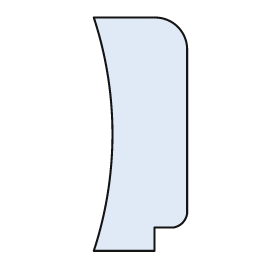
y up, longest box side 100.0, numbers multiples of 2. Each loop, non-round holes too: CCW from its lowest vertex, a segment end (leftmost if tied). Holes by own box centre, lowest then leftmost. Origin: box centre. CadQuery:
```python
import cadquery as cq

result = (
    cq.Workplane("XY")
    .moveTo(-20.0, -50.0)
    .lineTo(6.0, -50.0)
    .lineTo(6.0, -40.0)
    .lineTo(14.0, -40.0)
    .threePointArc((18.0, -38.0), (20.0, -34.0))
    .lineTo(20.0, 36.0)
    .threePointArc((16.0, 46.0), (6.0, 50.0))
    .lineTo(-20.0, 50.0)
    .threePointArc((-12.0, 0.0), (-20.0, -50.0))
    .close()
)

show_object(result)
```